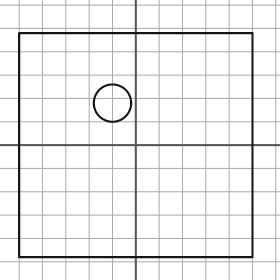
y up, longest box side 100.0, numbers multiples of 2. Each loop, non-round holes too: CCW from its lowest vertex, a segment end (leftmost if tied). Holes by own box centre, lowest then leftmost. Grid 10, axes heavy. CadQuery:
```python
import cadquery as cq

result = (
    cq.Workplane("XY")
    .moveTo(-50.0, -48.0)
    .lineTo(50.0, -48.0)
    .lineTo(50.0, 48.0)
    .lineTo(-50.0, 48.0)
    .close()
    .moveTo(-10.0, 18.0)
    .circle(8.0)
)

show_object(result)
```